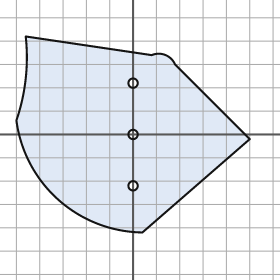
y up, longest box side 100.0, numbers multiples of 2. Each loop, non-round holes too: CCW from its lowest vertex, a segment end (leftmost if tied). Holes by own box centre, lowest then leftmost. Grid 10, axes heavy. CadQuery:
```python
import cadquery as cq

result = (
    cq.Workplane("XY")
    .moveTo(4.0, -42.0)
    .lineTo(50.0, -2.0)
    .lineTo(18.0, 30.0)
    .threePointArc((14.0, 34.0), (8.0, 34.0))
    .lineTo(-46.0, 42.0)
    .threePointArc((-46.0, 24.0), (-50.0, 6.0))
    .threePointArc((-32.0, -28.0), (4.0, -42.0))
    .close()
    .moveTo(0.0, -22.0)
    .circle(2.0)
    .moveTo(0.0, 0.0)
    .circle(2.0)
    .moveTo(0.0, 22.0)
    .circle(2.0)
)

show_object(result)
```